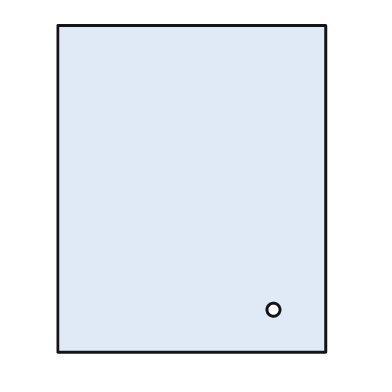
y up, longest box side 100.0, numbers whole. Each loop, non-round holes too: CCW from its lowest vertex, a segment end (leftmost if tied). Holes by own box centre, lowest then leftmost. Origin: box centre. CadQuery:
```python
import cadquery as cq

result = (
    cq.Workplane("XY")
    .moveTo(-41.0, -50.0)
    .lineTo(41.0, -50.0)
    .lineTo(41.0, 50.0)
    .lineTo(-41.0, 50.0)
    .close()
    .moveTo(25.0, -37.0)
    .circle(2.0)
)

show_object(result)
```